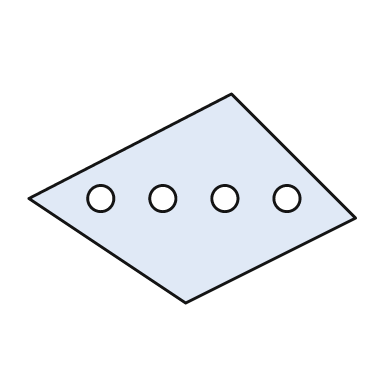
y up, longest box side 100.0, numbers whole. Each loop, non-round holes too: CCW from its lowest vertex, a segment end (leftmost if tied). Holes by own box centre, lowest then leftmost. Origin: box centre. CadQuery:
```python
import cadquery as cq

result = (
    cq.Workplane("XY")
    .moveTo(-2.0, -32.0)
    .lineTo(50.0, -6.0)
    .lineTo(12.0, 32.0)
    .lineTo(-50.0, 0.0)
    .close()
    .moveTo(-28.0, 0.0)
    .circle(4.0)
    .moveTo(-9.0, 0.0)
    .circle(4.0)
    .moveTo(10.0, 0.0)
    .circle(4.0)
    .moveTo(29.0, 0.0)
    .circle(4.0)
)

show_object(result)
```